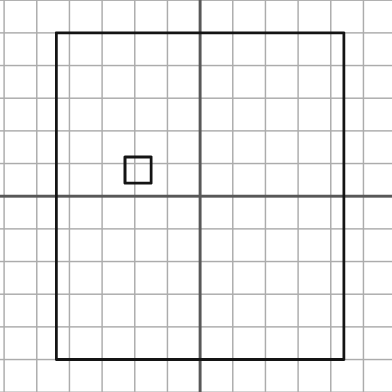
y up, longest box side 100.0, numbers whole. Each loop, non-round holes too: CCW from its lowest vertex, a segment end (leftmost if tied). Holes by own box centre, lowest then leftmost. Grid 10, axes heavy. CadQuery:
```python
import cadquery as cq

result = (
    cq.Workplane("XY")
    .moveTo(-44.0, -50.0)
    .lineTo(44.0, -50.0)
    .lineTo(44.0, 50.0)
    .lineTo(-44.0, 50.0)
    .close()
    .moveTo(-23.0, 4.0)
    .lineTo(-15.0, 4.0)
    .lineTo(-15.0, 12.0)
    .lineTo(-23.0, 12.0)
    .close()
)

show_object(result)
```